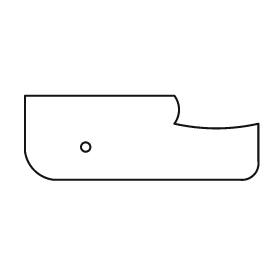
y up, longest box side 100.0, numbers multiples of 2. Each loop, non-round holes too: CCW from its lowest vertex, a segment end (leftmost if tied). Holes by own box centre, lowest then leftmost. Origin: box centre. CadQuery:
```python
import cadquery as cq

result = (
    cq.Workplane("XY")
    .moveTo(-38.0, -18.0)
    .lineTo(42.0, -18.0)
    .threePointArc((48.0, -16.0), (50.0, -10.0))
    .lineTo(50.0, 6.0)
    .threePointArc((32.0, 4.0), (14.0, 6.0))
    .threePointArc((16.0, 12.0), (14.0, 18.0))
    .lineTo(-50.0, 18.0)
    .lineTo(-50.0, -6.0)
    .threePointArc((-46.0, -14.0), (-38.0, -18.0))
    .close()
    .moveTo(-24.0, -4.0)
    .circle(2.0)
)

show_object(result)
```